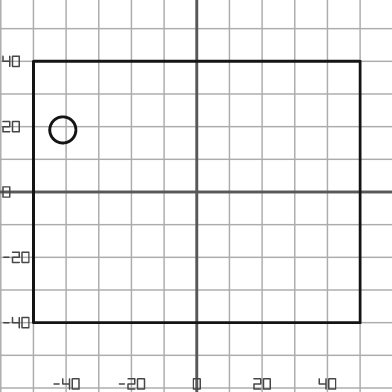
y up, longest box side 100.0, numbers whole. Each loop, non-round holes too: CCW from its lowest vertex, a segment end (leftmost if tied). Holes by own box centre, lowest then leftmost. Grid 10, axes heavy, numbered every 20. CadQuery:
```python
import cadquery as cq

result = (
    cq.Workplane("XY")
    .moveTo(-50.0, -40.0)
    .lineTo(50.0, -40.0)
    .lineTo(50.0, 40.0)
    .lineTo(-50.0, 40.0)
    .close()
    .moveTo(-41.0, 19.0)
    .circle(4.0)
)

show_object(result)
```